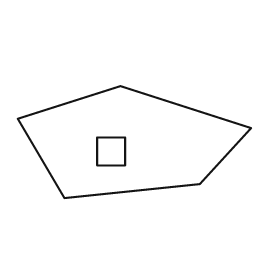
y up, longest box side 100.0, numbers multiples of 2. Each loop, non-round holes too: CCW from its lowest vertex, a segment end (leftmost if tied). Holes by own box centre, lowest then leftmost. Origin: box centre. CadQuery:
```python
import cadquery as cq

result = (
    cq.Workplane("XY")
    .moveTo(-30.0, -24.0)
    .lineTo(28.0, -18.0)
    .lineTo(50.0, 6.0)
    .lineTo(-6.0, 24.0)
    .lineTo(-50.0, 10.0)
    .close()
    .moveTo(-16.0, -10.0)
    .lineTo(-4.0, -10.0)
    .lineTo(-4.0, 2.0)
    .lineTo(-16.0, 2.0)
    .close()
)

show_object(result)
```